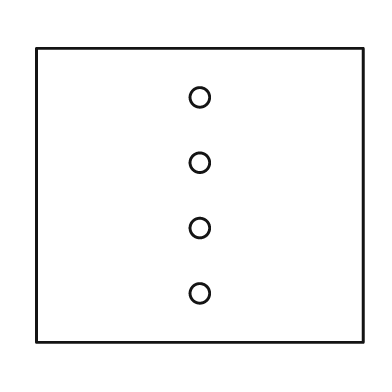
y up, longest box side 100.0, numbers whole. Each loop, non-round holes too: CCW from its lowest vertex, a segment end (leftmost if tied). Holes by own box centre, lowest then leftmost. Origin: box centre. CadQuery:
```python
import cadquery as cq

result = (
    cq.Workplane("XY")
    .moveTo(-50.0, -45.0)
    .lineTo(50.0, -45.0)
    .lineTo(50.0, 45.0)
    .lineTo(-50.0, 45.0)
    .close()
    .moveTo(0.0, -30.0)
    .circle(3.0)
    .moveTo(0.0, -10.0)
    .circle(3.0)
    .moveTo(0.0, 10.0)
    .circle(3.0)
    .moveTo(0.0, 30.0)
    .circle(3.0)
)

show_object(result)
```